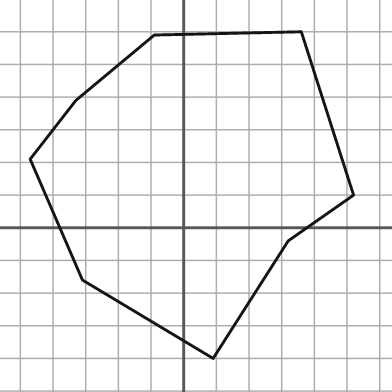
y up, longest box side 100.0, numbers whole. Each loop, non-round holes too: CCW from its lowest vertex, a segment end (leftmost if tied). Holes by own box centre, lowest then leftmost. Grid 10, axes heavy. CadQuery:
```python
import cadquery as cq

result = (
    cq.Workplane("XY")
    .moveTo(9.0, -40.0)
    .lineTo(32.0, -4.0)
    .lineTo(52.0, 10.0)
    .lineTo(36.0, 60.0)
    .lineTo(-9.0, 59.0)
    .lineTo(-33.0, 39.0)
    .lineTo(-47.0, 21.0)
    .lineTo(-31.0, -16.0)
    .close()
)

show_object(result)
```